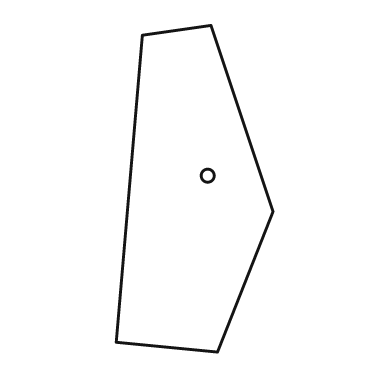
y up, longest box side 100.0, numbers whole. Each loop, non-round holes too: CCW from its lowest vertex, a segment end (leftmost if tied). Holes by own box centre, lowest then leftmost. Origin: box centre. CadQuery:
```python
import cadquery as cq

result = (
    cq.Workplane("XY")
    .moveTo(7.0, -50.0)
    .lineTo(24.0, -7.0)
    .lineTo(5.0, 50.0)
    .lineTo(-16.0, 47.0)
    .lineTo(-24.0, -47.0)
    .close()
    .moveTo(4.0, 4.0)
    .circle(2.0)
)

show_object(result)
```